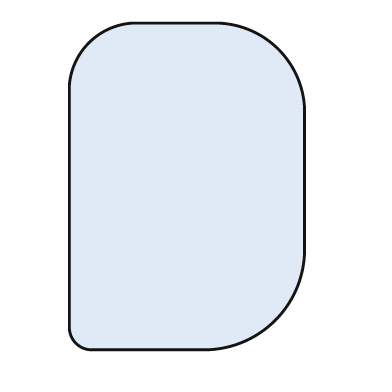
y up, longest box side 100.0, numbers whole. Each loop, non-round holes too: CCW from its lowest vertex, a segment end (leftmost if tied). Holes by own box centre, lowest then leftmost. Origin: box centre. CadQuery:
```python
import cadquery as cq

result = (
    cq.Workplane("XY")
    .moveTo(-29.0, -50.0)
    .lineTo(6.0, -50.0)
    .threePointArc((27.0, -41.0), (36.0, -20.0))
    .lineTo(36.0, 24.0)
    .threePointArc((28.0, 42.0), (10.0, 50.0))
    .lineTo(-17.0, 50.0)
    .threePointArc((-30.0, 44.0), (-36.0, 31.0))
    .lineTo(-36.0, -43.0)
    .threePointArc((-34.0, -48.0), (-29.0, -50.0))
    .close()
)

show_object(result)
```